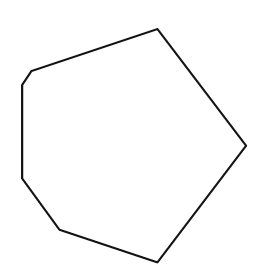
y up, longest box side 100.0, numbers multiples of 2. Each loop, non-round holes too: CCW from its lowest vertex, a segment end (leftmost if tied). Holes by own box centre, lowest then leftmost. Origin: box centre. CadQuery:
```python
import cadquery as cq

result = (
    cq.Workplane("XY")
    .moveTo(10.0, -50.0)
    .lineTo(48.0, 0.0)
    .lineTo(10.0, 50.0)
    .lineTo(-44.0, 32.0)
    .lineTo(-48.0, 26.0)
    .lineTo(-48.0, -14.0)
    .lineTo(-32.0, -36.0)
    .close()
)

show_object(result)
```